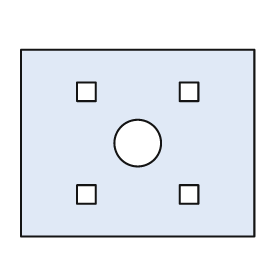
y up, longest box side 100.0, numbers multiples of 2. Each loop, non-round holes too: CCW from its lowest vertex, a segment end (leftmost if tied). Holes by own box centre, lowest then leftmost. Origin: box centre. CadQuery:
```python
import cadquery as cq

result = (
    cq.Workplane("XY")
    .moveTo(-50.0, -40.0)
    .lineTo(50.0, -40.0)
    .lineTo(50.0, 40.0)
    .lineTo(-50.0, 40.0)
    .close()
    .moveTo(-26.0, -26.0)
    .lineTo(-18.0, -26.0)
    .lineTo(-18.0, -18.0)
    .lineTo(-26.0, -18.0)
    .close()
    .moveTo(18.0, -26.0)
    .lineTo(26.0, -26.0)
    .lineTo(26.0, -18.0)
    .lineTo(18.0, -18.0)
    .close()
    .moveTo(0.0, 0.0)
    .circle(10.0)
    .moveTo(-26.0, 18.0)
    .lineTo(-18.0, 18.0)
    .lineTo(-18.0, 26.0)
    .lineTo(-26.0, 26.0)
    .close()
    .moveTo(18.0, 18.0)
    .lineTo(26.0, 18.0)
    .lineTo(26.0, 26.0)
    .lineTo(18.0, 26.0)
    .close()
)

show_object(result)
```